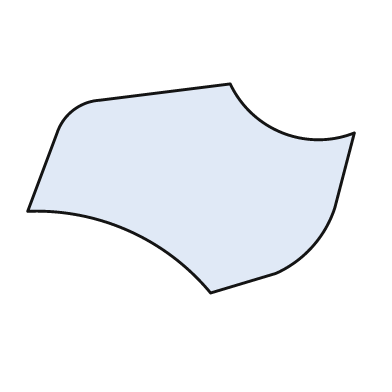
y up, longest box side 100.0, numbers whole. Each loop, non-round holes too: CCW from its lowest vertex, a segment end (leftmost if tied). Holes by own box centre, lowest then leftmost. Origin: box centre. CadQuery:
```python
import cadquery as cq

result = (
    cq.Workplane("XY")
    .moveTo(6.0, -32.0)
    .lineTo(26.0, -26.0)
    .threePointArc((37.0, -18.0), (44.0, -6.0))
    .lineTo(50.0, 17.0)
    .threePointArc((28.0, 17.0), (12.0, 32.0))
    .lineTo(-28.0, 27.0)
    .threePointArc((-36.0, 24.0), (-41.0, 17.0))
    .lineTo(-50.0, -7.0)
    .threePointArc((-19.0, -13.0), (6.0, -32.0))
    .close()
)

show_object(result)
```